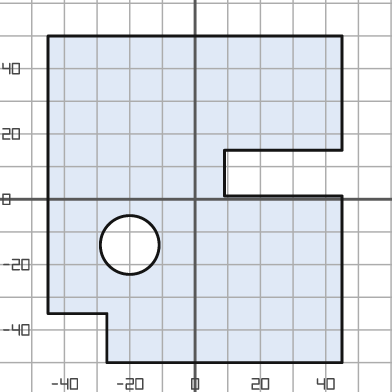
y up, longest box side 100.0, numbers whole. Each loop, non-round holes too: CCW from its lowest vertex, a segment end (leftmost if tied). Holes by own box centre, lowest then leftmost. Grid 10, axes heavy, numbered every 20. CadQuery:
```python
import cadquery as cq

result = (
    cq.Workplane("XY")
    .moveTo(-27.0, -50.0)
    .lineTo(45.0, -50.0)
    .lineTo(45.0, 1.0)
    .lineTo(9.0, 1.0)
    .lineTo(9.0, 15.0)
    .lineTo(45.0, 15.0)
    .lineTo(45.0, 50.0)
    .lineTo(-45.0, 50.0)
    .lineTo(-45.0, -35.0)
    .lineTo(-27.0, -35.0)
    .close()
    .moveTo(-20.0, -14.0)
    .circle(9.0)
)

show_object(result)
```